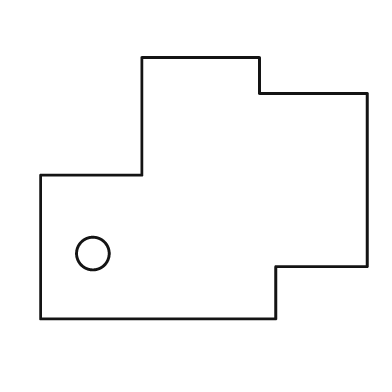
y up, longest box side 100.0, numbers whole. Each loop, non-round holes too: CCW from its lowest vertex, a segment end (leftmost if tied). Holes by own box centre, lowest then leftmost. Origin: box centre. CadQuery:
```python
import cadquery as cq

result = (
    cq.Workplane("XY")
    .moveTo(-50.0, -40.0)
    .lineTo(22.0, -40.0)
    .lineTo(22.0, -24.0)
    .lineTo(50.0, -24.0)
    .lineTo(50.0, 29.0)
    .lineTo(17.0, 29.0)
    .lineTo(17.0, 40.0)
    .lineTo(-19.0, 40.0)
    .lineTo(-19.0, 4.0)
    .lineTo(-50.0, 4.0)
    .close()
    .moveTo(-34.0, -20.0)
    .circle(5.0)
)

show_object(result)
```